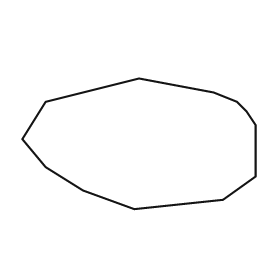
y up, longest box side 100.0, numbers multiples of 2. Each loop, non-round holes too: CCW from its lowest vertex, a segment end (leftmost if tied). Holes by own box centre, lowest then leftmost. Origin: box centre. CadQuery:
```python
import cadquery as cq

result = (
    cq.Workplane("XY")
    .moveTo(-2.0, -28.0)
    .lineTo(36.0, -24.0)
    .lineTo(50.0, -14.0)
    .lineTo(50.0, 8.0)
    .lineTo(46.0, 14.0)
    .lineTo(42.0, 18.0)
    .lineTo(32.0, 22.0)
    .lineTo(0.0, 28.0)
    .lineTo(-40.0, 18.0)
    .lineTo(-50.0, 2.0)
    .lineTo(-40.0, -10.0)
    .lineTo(-24.0, -20.0)
    .close()
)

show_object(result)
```